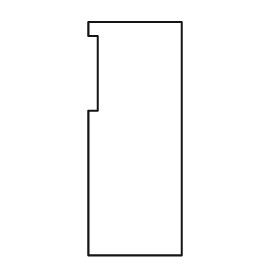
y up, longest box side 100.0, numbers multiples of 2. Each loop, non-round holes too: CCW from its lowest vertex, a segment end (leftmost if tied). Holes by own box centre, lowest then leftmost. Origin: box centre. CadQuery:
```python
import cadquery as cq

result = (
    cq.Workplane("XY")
    .moveTo(-20.0, -50.0)
    .lineTo(20.0, -50.0)
    .lineTo(20.0, 50.0)
    .lineTo(-20.0, 50.0)
    .lineTo(-20.0, 44.0)
    .lineTo(-16.0, 44.0)
    .lineTo(-16.0, 12.0)
    .lineTo(-20.0, 12.0)
    .close()
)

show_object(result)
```